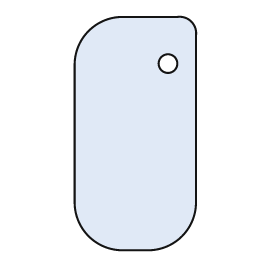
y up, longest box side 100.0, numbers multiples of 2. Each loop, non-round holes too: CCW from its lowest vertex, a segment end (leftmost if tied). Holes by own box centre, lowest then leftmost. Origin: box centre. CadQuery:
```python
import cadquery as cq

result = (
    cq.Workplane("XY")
    .moveTo(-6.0, -50.0)
    .lineTo(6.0, -50.0)
    .threePointArc((20.0, -44.0), (26.0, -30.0))
    .lineTo(26.0, 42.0)
    .threePointArc((24.0, 48.0), (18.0, 50.0))
    .lineTo(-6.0, 50.0)
    .threePointArc((-20.0, 44.0), (-26.0, 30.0))
    .lineTo(-26.0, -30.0)
    .threePointArc((-20.0, -44.0), (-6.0, -50.0))
    .close()
    .moveTo(14.0, 30.0)
    .circle(4.0)
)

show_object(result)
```